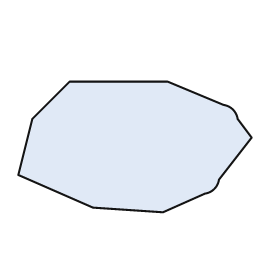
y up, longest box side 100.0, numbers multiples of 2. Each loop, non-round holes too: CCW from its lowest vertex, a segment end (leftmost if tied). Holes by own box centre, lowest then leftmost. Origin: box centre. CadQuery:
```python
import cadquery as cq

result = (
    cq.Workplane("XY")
    .moveTo(12.0, -28.0)
    .lineTo(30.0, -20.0)
    .threePointArc((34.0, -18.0), (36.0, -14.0))
    .lineTo(50.0, 4.0)
    .lineTo(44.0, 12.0)
    .threePointArc((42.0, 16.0), (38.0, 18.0))
    .lineTo(14.0, 28.0)
    .lineTo(-28.0, 28.0)
    .lineTo(-44.0, 12.0)
    .lineTo(-50.0, -12.0)
    .lineTo(-18.0, -26.0)
    .close()
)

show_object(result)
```